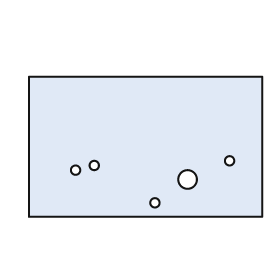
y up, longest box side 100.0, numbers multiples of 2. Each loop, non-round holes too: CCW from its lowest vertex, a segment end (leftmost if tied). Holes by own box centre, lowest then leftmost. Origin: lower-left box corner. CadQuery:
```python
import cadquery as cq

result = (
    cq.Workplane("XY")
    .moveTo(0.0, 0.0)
    .lineTo(100.0, 0.0)
    .lineTo(100.0, 60.0)
    .lineTo(0.0, 60.0)
    .close()
    .moveTo(54.0, 6.0)
    .circle(2.0)
    .moveTo(68.0, 16.0)
    .circle(4.0)
    .moveTo(20.0, 20.0)
    .circle(2.0)
    .moveTo(28.0, 22.0)
    .circle(2.0)
    .moveTo(86.0, 24.0)
    .circle(2.0)
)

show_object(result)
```